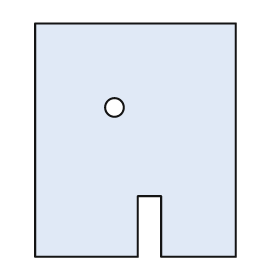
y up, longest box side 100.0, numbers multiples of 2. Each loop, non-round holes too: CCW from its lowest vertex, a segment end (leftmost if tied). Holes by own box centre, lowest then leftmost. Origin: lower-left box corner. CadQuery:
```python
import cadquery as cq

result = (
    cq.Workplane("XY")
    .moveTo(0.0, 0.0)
    .lineTo(44.0, 0.0)
    .lineTo(44.0, 26.0)
    .lineTo(54.0, 26.0)
    .lineTo(54.0, 0.0)
    .lineTo(86.0, 0.0)
    .lineTo(86.0, 100.0)
    .lineTo(0.0, 100.0)
    .close()
    .moveTo(34.0, 64.0)
    .circle(4.0)
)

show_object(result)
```